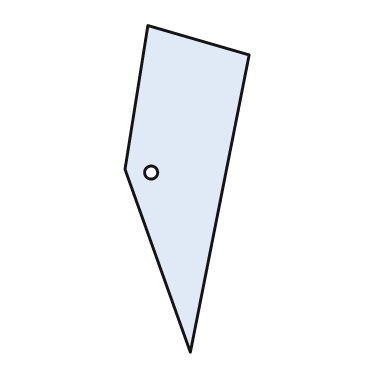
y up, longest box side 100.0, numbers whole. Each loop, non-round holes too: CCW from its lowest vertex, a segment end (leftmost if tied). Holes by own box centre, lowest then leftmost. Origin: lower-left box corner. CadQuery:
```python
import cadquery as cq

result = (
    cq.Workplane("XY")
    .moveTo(20.0, 0.0)
    .lineTo(38.0, 91.0)
    .lineTo(7.0, 100.0)
    .lineTo(0.0, 56.0)
    .close()
    .moveTo(8.0, 55.0)
    .circle(2.0)
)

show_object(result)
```